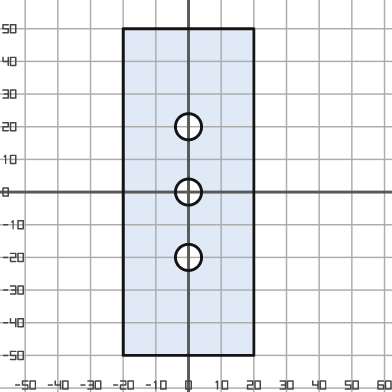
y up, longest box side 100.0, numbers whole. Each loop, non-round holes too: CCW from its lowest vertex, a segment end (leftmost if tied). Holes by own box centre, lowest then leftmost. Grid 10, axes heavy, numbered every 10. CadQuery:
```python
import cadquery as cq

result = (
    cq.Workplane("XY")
    .moveTo(-20.0, -50.0)
    .lineTo(20.0, -50.0)
    .lineTo(20.0, 50.0)
    .lineTo(-20.0, 50.0)
    .close()
    .moveTo(0.0, -20.0)
    .circle(4.0)
    .moveTo(0.0, 0.0)
    .circle(4.0)
    .moveTo(0.0, 20.0)
    .circle(4.0)
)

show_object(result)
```